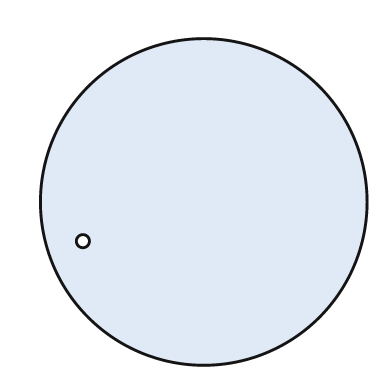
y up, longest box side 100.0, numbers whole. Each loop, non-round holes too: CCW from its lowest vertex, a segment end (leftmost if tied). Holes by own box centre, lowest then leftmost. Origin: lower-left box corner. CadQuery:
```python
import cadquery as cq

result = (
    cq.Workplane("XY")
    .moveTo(50.0, 50.0)
    .circle(50.0)
    .moveTo(13.0, 38.0)
    .circle(2.0)
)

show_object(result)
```